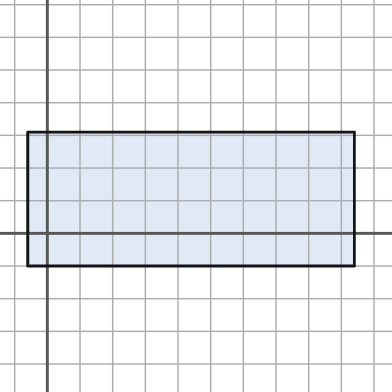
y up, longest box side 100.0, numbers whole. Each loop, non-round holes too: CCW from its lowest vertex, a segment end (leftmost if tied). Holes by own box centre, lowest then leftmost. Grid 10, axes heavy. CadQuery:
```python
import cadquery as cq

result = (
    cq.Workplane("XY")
    .moveTo(-6.0, -10.0)
    .lineTo(94.0, -10.0)
    .lineTo(94.0, 31.0)
    .lineTo(-6.0, 31.0)
    .close()
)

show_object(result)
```